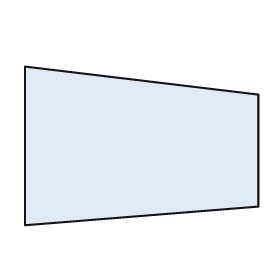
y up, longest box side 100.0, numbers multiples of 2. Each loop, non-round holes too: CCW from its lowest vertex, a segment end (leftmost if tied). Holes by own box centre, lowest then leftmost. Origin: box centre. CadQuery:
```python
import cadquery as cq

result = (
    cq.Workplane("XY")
    .moveTo(-50.0, -34.0)
    .lineTo(50.0, -26.0)
    .lineTo(50.0, 22.0)
    .lineTo(-50.0, 34.0)
    .close()
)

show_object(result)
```